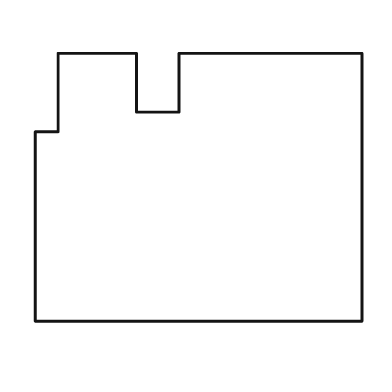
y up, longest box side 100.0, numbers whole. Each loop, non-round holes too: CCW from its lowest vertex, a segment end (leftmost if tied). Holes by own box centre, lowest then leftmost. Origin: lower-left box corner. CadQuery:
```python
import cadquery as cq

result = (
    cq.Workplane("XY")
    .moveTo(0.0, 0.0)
    .lineTo(100.0, 0.0)
    .lineTo(100.0, 82.0)
    .lineTo(44.0, 82.0)
    .lineTo(44.0, 64.0)
    .lineTo(31.0, 64.0)
    .lineTo(31.0, 82.0)
    .lineTo(7.0, 82.0)
    .lineTo(7.0, 58.0)
    .lineTo(0.0, 58.0)
    .close()
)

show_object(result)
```